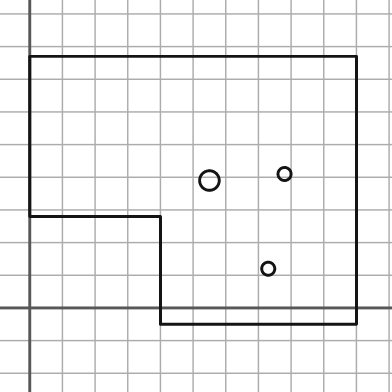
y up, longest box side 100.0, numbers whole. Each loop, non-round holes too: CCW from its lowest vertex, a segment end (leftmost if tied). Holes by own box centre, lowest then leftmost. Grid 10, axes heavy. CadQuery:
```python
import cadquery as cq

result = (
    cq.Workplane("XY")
    .moveTo(40.0, -5.0)
    .lineTo(100.0, -5.0)
    .lineTo(100.0, 77.0)
    .lineTo(0.0, 77.0)
    .lineTo(0.0, 28.0)
    .lineTo(40.0, 28.0)
    .close()
    .moveTo(73.0, 12.0)
    .circle(2.0)
    .moveTo(55.0, 39.0)
    .circle(3.0)
    .moveTo(78.0, 41.0)
    .circle(2.0)
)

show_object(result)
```